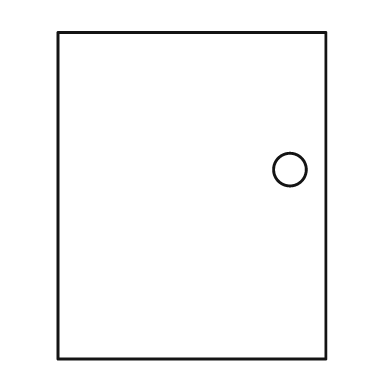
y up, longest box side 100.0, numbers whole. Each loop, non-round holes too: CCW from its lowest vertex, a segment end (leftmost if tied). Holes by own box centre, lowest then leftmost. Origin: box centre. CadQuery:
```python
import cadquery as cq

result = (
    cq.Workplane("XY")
    .moveTo(-41.0, -50.0)
    .lineTo(41.0, -50.0)
    .lineTo(41.0, 50.0)
    .lineTo(-41.0, 50.0)
    .close()
    .moveTo(30.0, 8.0)
    .circle(5.0)
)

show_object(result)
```